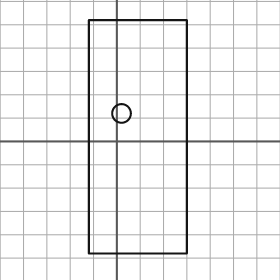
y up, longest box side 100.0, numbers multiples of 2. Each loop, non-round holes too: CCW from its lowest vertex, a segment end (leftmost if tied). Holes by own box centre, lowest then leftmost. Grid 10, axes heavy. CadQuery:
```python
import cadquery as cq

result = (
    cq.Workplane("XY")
    .moveTo(-12.0, -48.0)
    .lineTo(30.0, -48.0)
    .lineTo(30.0, 52.0)
    .lineTo(-12.0, 52.0)
    .close()
    .moveTo(2.0, 12.0)
    .circle(4.0)
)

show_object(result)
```